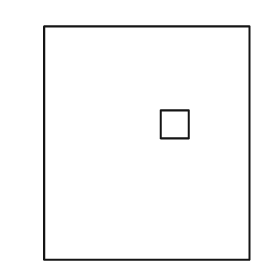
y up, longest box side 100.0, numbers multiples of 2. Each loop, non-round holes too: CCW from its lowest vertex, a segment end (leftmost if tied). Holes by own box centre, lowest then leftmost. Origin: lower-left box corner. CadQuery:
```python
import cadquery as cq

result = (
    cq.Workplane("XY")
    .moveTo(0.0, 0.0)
    .lineTo(88.0, 0.0)
    .lineTo(88.0, 100.0)
    .lineTo(0.0, 100.0)
    .close()
    .moveTo(50.0, 52.0)
    .lineTo(62.0, 52.0)
    .lineTo(62.0, 64.0)
    .lineTo(50.0, 64.0)
    .close()
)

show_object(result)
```